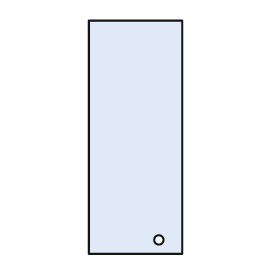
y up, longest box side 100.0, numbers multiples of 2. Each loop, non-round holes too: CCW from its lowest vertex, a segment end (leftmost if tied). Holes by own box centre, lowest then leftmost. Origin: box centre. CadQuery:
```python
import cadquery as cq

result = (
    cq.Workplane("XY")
    .moveTo(-20.0, -50.0)
    .lineTo(20.0, -50.0)
    .lineTo(20.0, 50.0)
    .lineTo(-20.0, 50.0)
    .close()
    .moveTo(10.0, -44.0)
    .circle(2.0)
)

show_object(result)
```